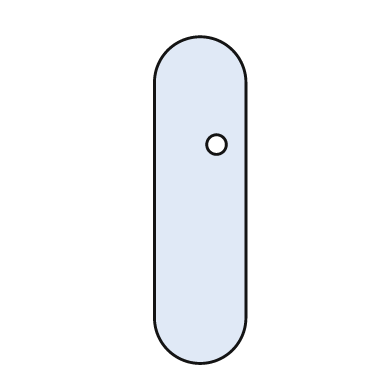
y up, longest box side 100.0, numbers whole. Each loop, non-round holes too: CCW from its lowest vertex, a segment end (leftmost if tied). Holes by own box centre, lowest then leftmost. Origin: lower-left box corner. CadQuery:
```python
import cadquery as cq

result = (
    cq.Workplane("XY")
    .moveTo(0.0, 14.0)
    .threePointArc((14.0, 0.0), (28.0, 14.0))
    .lineTo(28.0, 86.0)
    .threePointArc((14.0, 100.0), (0.0, 86.0))
    .close()
    .moveTo(19.0, 67.0)
    .circle(3.0)
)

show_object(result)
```